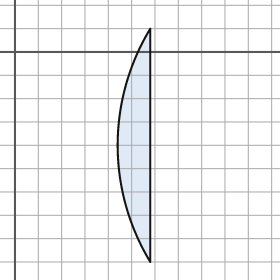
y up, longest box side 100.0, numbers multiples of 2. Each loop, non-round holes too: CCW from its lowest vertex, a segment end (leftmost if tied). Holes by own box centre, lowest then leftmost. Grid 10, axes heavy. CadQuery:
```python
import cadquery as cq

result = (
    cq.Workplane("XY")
    .moveTo(58.0, -90.0)
    .lineTo(58.0, 10.0)
    .threePointArc((44.0, -40.0), (58.0, -90.0))
    .close()
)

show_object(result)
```